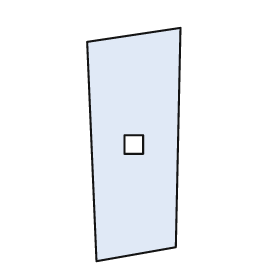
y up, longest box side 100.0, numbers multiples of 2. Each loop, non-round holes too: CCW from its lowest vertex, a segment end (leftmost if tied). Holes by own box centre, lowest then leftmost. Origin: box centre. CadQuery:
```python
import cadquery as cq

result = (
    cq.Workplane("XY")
    .moveTo(-16.0, -50.0)
    .lineTo(18.0, -44.0)
    .lineTo(20.0, 50.0)
    .lineTo(-20.0, 44.0)
    .close()
    .moveTo(-4.0, -4.0)
    .lineTo(4.0, -4.0)
    .lineTo(4.0, 4.0)
    .lineTo(-4.0, 4.0)
    .close()
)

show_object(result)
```